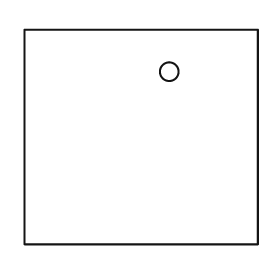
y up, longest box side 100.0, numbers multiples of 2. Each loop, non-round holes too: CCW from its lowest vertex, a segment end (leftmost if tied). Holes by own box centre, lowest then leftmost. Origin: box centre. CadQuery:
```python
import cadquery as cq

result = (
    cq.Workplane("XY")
    .moveTo(-50.0, -46.0)
    .lineTo(50.0, -46.0)
    .lineTo(50.0, 46.0)
    .lineTo(-50.0, 46.0)
    .close()
    .moveTo(12.0, 28.0)
    .circle(4.0)
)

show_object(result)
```